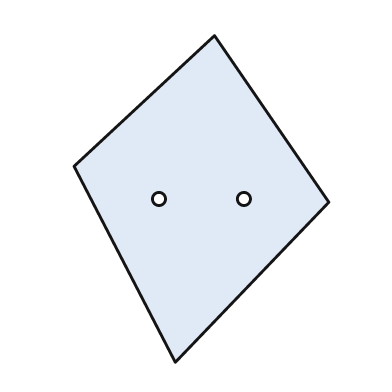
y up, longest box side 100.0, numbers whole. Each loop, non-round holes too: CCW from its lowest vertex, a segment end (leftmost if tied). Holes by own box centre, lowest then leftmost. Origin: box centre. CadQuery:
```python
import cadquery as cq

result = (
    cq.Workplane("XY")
    .moveTo(-8.0, -50.0)
    .lineTo(39.0, -1.0)
    .lineTo(4.0, 50.0)
    .lineTo(-39.0, 10.0)
    .close()
    .moveTo(-13.0, 0.0)
    .circle(2.0)
    .moveTo(13.0, 0.0)
    .circle(2.0)
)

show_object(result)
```